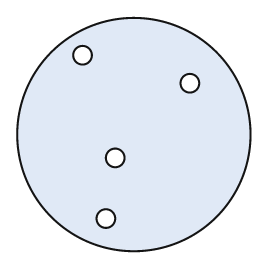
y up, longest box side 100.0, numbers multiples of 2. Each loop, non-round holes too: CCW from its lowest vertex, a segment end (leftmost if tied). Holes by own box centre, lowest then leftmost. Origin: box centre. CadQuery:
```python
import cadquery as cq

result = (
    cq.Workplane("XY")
    .moveTo(0.0, 0.0)
    .circle(50.0)
    .moveTo(-12.0, -36.0)
    .circle(4.0)
    .moveTo(-8.0, -10.0)
    .circle(4.0)
    .moveTo(24.0, 22.0)
    .circle(4.0)
    .moveTo(-22.0, 34.0)
    .circle(4.0)
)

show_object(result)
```